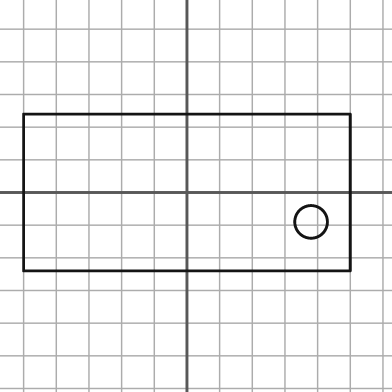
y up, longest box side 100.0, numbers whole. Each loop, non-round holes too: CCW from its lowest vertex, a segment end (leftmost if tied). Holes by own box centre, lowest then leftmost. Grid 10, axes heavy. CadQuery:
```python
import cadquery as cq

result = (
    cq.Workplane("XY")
    .moveTo(-50.0, -24.0)
    .lineTo(50.0, -24.0)
    .lineTo(50.0, 24.0)
    .lineTo(-50.0, 24.0)
    .close()
    .moveTo(38.0, -9.0)
    .circle(5.0)
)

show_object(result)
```